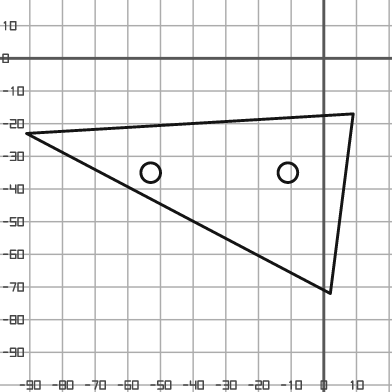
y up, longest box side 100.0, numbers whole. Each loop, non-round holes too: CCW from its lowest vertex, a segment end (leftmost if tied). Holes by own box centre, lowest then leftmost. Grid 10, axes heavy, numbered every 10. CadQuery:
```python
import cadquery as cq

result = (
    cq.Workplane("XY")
    .moveTo(2.0, -72.0)
    .lineTo(9.0, -17.0)
    .lineTo(-91.0, -23.0)
    .close()
    .moveTo(-53.0, -35.0)
    .circle(3.0)
    .moveTo(-11.0, -35.0)
    .circle(3.0)
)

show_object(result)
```